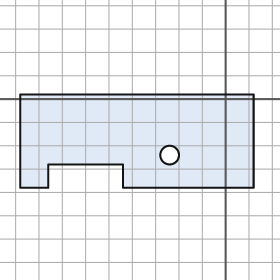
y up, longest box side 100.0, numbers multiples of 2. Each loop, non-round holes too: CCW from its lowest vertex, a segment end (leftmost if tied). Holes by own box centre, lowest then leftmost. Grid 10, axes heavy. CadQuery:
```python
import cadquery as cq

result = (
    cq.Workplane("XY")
    .moveTo(-88.0, -38.0)
    .lineTo(-76.0, -38.0)
    .lineTo(-76.0, -28.0)
    .lineTo(-44.0, -28.0)
    .lineTo(-44.0, -38.0)
    .lineTo(12.0, -38.0)
    .lineTo(12.0, 2.0)
    .lineTo(-88.0, 2.0)
    .close()
    .moveTo(-24.0, -24.0)
    .circle(4.0)
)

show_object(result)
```